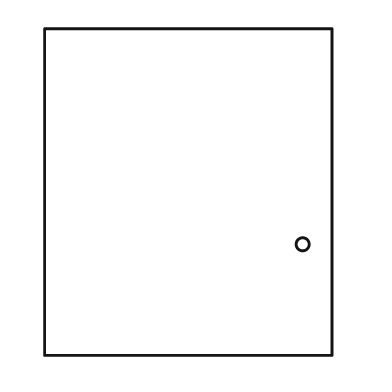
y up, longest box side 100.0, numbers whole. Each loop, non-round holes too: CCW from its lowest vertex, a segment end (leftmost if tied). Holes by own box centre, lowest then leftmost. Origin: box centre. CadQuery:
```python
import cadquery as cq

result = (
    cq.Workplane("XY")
    .moveTo(-44.0, -50.0)
    .lineTo(44.0, -50.0)
    .lineTo(44.0, 50.0)
    .lineTo(-44.0, 50.0)
    .close()
    .moveTo(35.0, -16.0)
    .circle(2.0)
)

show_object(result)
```